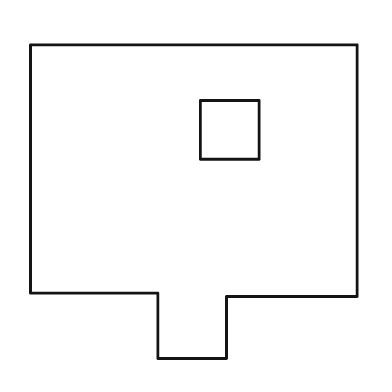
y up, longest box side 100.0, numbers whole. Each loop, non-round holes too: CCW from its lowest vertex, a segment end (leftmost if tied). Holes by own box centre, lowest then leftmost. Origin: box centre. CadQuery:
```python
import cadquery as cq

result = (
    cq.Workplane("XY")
    .moveTo(-11.0, -48.0)
    .lineTo(10.0, -48.0)
    .lineTo(10.0, -29.0)
    .lineTo(50.0, -29.0)
    .lineTo(50.0, 48.0)
    .lineTo(-50.0, 48.0)
    .lineTo(-50.0, -28.0)
    .lineTo(-11.0, -28.0)
    .close()
    .moveTo(2.0, 13.0)
    .lineTo(20.0, 13.0)
    .lineTo(20.0, 31.0)
    .lineTo(2.0, 31.0)
    .close()
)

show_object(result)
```